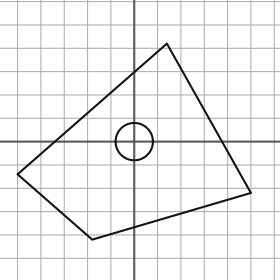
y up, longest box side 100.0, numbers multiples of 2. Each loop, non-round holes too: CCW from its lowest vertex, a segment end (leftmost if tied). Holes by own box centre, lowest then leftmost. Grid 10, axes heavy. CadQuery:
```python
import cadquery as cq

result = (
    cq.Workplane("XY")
    .moveTo(-18.0, -42.0)
    .lineTo(50.0, -22.0)
    .lineTo(14.0, 42.0)
    .lineTo(-50.0, -14.0)
    .close()
    .moveTo(0.0, 0.0)
    .circle(8.0)
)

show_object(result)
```